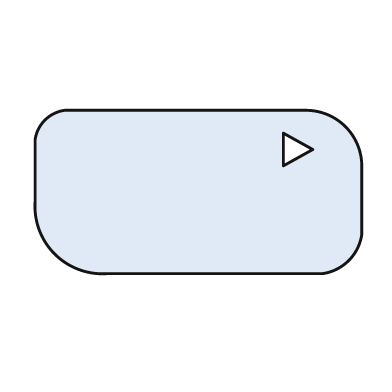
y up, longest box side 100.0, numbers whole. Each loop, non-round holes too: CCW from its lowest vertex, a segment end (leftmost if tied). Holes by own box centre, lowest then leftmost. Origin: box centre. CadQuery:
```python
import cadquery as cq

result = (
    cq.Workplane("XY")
    .moveTo(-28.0, -25.0)
    .lineTo(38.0, -25.0)
    .threePointArc((46.0, -21.0), (50.0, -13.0))
    .lineTo(50.0, 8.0)
    .threePointArc((45.0, 20.0), (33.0, 25.0))
    .lineTo(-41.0, 25.0)
    .threePointArc((-47.0, 22.0), (-50.0, 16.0))
    .lineTo(-50.0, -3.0)
    .threePointArc((-44.0, -19.0), (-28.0, -25.0))
    .close()
    .moveTo(26.0, 8.0)
    .lineTo(35.0, 13.0)
    .lineTo(26.0, 18.0)
    .close()
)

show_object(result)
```